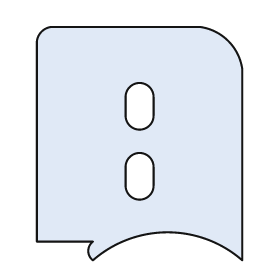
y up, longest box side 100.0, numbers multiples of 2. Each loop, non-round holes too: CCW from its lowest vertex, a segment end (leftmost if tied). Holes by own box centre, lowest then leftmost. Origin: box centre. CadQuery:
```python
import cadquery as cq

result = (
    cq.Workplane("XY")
    .moveTo(-20.0, -50.0)
    .threePointArc((12.0, -38.0), (44.0, -50.0))
    .lineTo(44.0, 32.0)
    .threePointArc((38.0, 44.0), (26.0, 50.0))
    .lineTo(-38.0, 50.0)
    .threePointArc((-42.0, 48.0), (-44.0, 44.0))
    .lineTo(-44.0, -42.0)
    .lineTo(-20.0, -42.0)
    .threePointArc((-22.0, -46.0), (-20.0, -50.0))
    .close()
    .moveTo(-6.0, -18.0)
    .threePointArc((0.0, -24.0), (6.0, -18.0))
    .lineTo(6.0, -10.0)
    .threePointArc((0.0, -4.0), (-6.0, -10.0))
    .close()
    .moveTo(-6.0, 12.0)
    .threePointArc((0.0, 6.0), (6.0, 12.0))
    .lineTo(6.0, 20.0)
    .threePointArc((0.0, 26.0), (-6.0, 20.0))
    .close()
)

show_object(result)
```